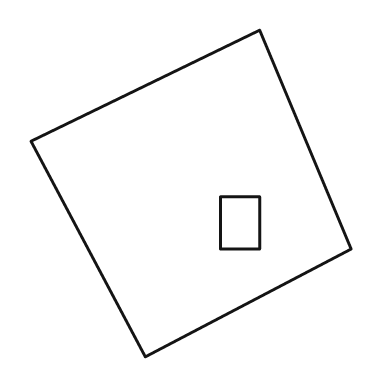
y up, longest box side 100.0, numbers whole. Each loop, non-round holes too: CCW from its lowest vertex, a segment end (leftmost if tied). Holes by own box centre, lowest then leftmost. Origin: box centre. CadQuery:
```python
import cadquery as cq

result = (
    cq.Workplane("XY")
    .moveTo(-14.0, -50.0)
    .lineTo(49.0, -17.0)
    .lineTo(21.0, 50.0)
    .lineTo(-49.0, 16.0)
    .close()
    .moveTo(9.0, -17.0)
    .lineTo(21.0, -17.0)
    .lineTo(21.0, -1.0)
    .lineTo(9.0, -1.0)
    .close()
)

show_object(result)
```